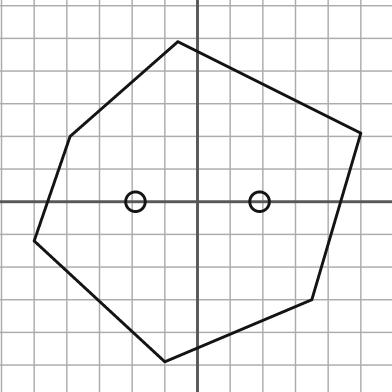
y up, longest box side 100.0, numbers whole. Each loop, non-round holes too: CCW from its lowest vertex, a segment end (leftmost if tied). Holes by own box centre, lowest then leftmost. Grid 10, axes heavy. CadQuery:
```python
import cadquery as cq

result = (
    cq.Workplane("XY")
    .moveTo(-10.0, -49.0)
    .lineTo(35.0, -30.0)
    .lineTo(50.0, 21.0)
    .lineTo(-6.0, 49.0)
    .lineTo(-39.0, 20.0)
    .lineTo(-50.0, -12.0)
    .close()
    .moveTo(-19.0, 0.0)
    .circle(3.0)
    .moveTo(19.0, 0.0)
    .circle(3.0)
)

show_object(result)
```